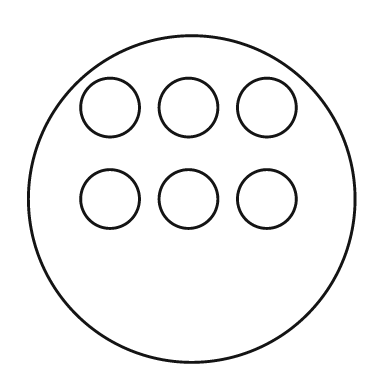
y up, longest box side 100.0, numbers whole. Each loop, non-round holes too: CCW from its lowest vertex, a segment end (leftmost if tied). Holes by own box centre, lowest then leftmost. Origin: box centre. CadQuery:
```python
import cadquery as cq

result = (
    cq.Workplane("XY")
    .moveTo(0.0, 0.0)
    .circle(50.0)
    .moveTo(-25.0, 0.0)
    .circle(9.0)
    .moveTo(-1.0, 0.0)
    .circle(9.0)
    .moveTo(23.0, 0.0)
    .circle(9.0)
    .moveTo(-25.0, 28.0)
    .circle(9.0)
    .moveTo(-1.0, 28.0)
    .circle(9.0)
    .moveTo(23.0, 28.0)
    .circle(9.0)
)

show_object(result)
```